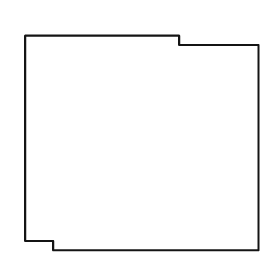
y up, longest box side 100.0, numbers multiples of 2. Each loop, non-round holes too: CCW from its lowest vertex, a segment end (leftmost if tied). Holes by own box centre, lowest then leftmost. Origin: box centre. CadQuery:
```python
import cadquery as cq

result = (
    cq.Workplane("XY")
    .moveTo(-38.0, -46.0)
    .lineTo(50.0, -46.0)
    .lineTo(50.0, 42.0)
    .lineTo(16.0, 42.0)
    .lineTo(16.0, 46.0)
    .lineTo(-50.0, 46.0)
    .lineTo(-50.0, -42.0)
    .lineTo(-38.0, -42.0)
    .close()
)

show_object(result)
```